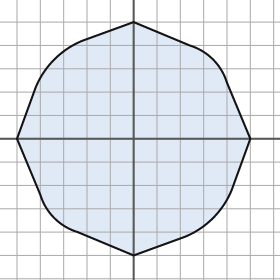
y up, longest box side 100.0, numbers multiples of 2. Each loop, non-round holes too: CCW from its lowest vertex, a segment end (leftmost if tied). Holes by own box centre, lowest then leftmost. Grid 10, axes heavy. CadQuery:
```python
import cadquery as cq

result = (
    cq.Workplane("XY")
    .moveTo(0.0, -50.0)
    .lineTo(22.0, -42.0)
    .threePointArc((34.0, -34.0), (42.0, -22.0))
    .lineTo(50.0, 0.0)
    .lineTo(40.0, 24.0)
    .threePointArc((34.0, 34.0), (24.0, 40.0))
    .lineTo(0.0, 50.0)
    .lineTo(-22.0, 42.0)
    .threePointArc((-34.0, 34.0), (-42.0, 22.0))
    .lineTo(-50.0, 0.0)
    .lineTo(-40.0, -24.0)
    .threePointArc((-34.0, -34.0), (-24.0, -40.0))
    .close()
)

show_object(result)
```